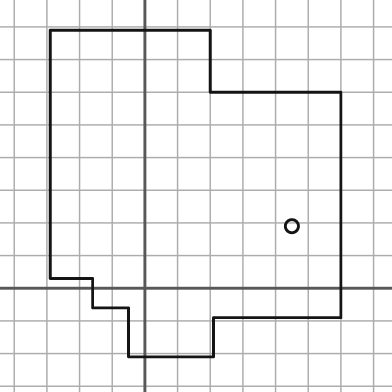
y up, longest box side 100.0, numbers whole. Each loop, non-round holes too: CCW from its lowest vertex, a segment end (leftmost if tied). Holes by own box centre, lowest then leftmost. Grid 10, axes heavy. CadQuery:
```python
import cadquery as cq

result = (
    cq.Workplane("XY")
    .moveTo(-5.0, -21.0)
    .lineTo(21.0, -21.0)
    .lineTo(21.0, -9.0)
    .lineTo(60.0, -9.0)
    .lineTo(60.0, 60.0)
    .lineTo(20.0, 60.0)
    .lineTo(20.0, 79.0)
    .lineTo(-29.0, 79.0)
    .lineTo(-29.0, 3.0)
    .lineTo(-16.0, 3.0)
    .lineTo(-16.0, -6.0)
    .lineTo(-5.0, -6.0)
    .close()
    .moveTo(45.0, 19.0)
    .circle(2.0)
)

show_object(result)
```